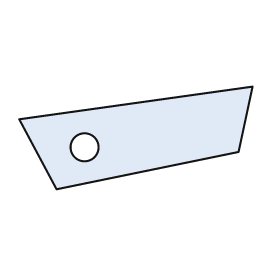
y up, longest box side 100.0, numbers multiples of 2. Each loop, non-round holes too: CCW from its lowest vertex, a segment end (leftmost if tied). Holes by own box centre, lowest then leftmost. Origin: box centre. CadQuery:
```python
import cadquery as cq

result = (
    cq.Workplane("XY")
    .moveTo(-34.0, -22.0)
    .lineTo(44.0, -6.0)
    .lineTo(50.0, 22.0)
    .lineTo(-50.0, 8.0)
    .close()
    .moveTo(-22.0, -4.0)
    .circle(6.0)
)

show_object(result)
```